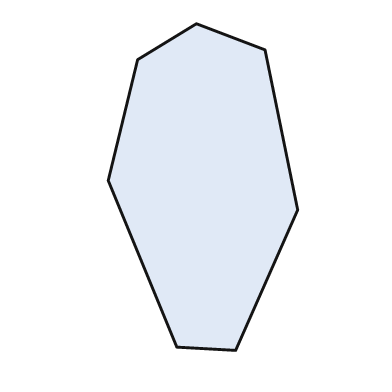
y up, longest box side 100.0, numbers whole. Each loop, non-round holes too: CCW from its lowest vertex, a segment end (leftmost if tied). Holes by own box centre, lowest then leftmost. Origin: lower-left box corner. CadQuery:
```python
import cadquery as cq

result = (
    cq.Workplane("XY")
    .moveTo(39.0, 0.0)
    .lineTo(58.0, 43.0)
    .lineTo(48.0, 92.0)
    .lineTo(27.0, 100.0)
    .lineTo(9.0, 89.0)
    .lineTo(0.0, 52.0)
    .lineTo(21.0, 1.0)
    .close()
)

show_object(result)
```